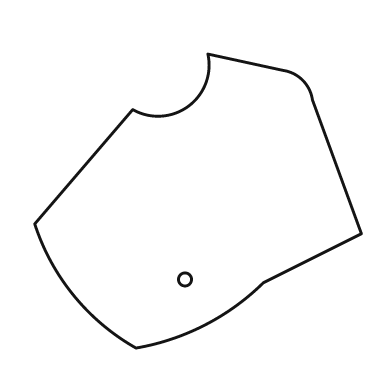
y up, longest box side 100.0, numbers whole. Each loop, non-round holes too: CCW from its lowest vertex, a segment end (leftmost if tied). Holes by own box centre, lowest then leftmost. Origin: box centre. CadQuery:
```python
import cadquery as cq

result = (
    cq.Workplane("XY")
    .moveTo(-19.0, -45.0)
    .threePointArc((2.0, -38.0), (20.0, -25.0))
    .lineTo(50.0, -10.0)
    .lineTo(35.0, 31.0)
    .threePointArc((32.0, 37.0), (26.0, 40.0))
    .lineTo(3.0, 45.0)
    .threePointArc((-3.0, 29.0), (-20.0, 28.0))
    .lineTo(-50.0, -7.0)
    .threePointArc((-38.0, -29.0), (-19.0, -45.0))
    .close()
    .moveTo(-4.0, -24.0)
    .circle(2.0)
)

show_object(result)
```